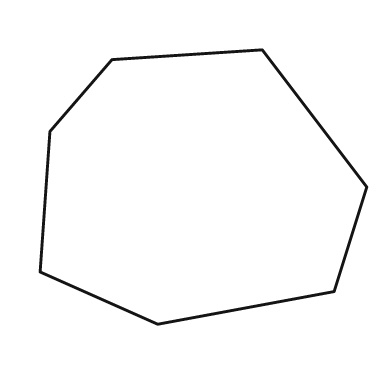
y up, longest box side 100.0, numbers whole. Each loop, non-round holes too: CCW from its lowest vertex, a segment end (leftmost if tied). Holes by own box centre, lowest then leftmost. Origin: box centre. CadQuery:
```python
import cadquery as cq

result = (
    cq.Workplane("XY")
    .moveTo(-14.0, -42.0)
    .lineTo(40.0, -32.0)
    .lineTo(50.0, 0.0)
    .lineTo(18.0, 42.0)
    .lineTo(-28.0, 39.0)
    .lineTo(-47.0, 17.0)
    .lineTo(-50.0, -26.0)
    .close()
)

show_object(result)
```